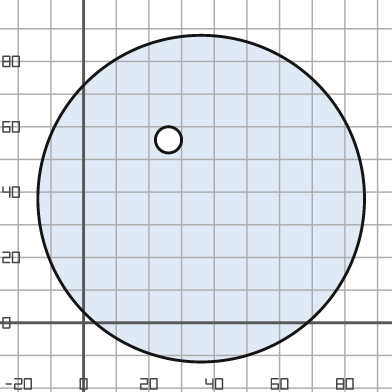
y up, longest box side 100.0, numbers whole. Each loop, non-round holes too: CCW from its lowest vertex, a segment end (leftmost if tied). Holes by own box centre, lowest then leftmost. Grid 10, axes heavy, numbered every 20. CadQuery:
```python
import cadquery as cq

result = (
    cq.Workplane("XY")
    .moveTo(36.0, 38.0)
    .circle(50.0)
    .moveTo(26.0, 56.0)
    .circle(4.0)
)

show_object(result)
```